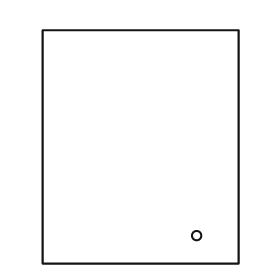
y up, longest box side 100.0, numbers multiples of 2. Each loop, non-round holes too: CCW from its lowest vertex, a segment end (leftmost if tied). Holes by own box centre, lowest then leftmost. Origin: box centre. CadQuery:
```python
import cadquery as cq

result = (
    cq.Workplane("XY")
    .moveTo(-42.0, -50.0)
    .lineTo(42.0, -50.0)
    .lineTo(42.0, 50.0)
    .lineTo(-42.0, 50.0)
    .close()
    .moveTo(24.0, -38.0)
    .circle(2.0)
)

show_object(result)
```